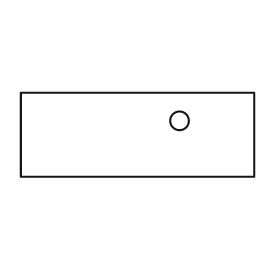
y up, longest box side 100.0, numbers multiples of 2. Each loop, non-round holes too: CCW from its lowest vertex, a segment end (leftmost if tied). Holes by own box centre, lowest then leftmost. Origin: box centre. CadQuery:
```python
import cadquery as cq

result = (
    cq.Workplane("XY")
    .moveTo(-50.0, -18.0)
    .lineTo(50.0, -18.0)
    .lineTo(50.0, 18.0)
    .lineTo(-50.0, 18.0)
    .close()
    .moveTo(18.0, 6.0)
    .circle(4.0)
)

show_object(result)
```